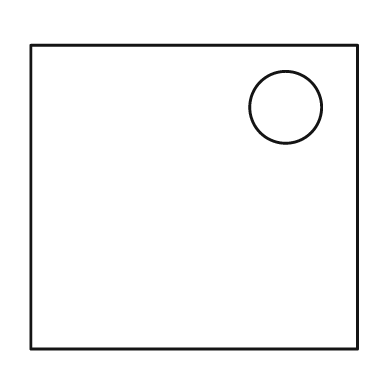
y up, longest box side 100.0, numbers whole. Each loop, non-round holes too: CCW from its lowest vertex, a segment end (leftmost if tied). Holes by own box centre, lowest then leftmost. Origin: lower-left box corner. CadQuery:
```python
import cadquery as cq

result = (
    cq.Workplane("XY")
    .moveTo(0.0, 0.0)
    .lineTo(100.0, 0.0)
    .lineTo(100.0, 93.0)
    .lineTo(0.0, 93.0)
    .close()
    .moveTo(78.0, 74.0)
    .circle(11.0)
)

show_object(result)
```